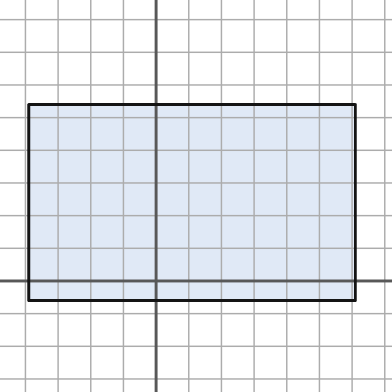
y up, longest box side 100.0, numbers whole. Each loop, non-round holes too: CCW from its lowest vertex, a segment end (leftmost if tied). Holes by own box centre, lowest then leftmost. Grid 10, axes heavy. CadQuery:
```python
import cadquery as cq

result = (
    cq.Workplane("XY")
    .moveTo(-39.0, -6.0)
    .lineTo(61.0, -6.0)
    .lineTo(61.0, 54.0)
    .lineTo(-39.0, 54.0)
    .close()
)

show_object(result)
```